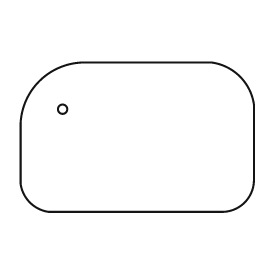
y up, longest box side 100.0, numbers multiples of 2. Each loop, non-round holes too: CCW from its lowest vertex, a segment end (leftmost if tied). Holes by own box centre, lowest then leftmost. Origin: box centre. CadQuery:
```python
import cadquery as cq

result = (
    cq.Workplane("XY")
    .moveTo(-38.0, -32.0)
    .lineTo(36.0, -32.0)
    .threePointArc((46.0, -28.0), (50.0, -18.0))
    .lineTo(50.0, 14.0)
    .threePointArc((44.0, 26.0), (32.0, 32.0))
    .lineTo(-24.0, 32.0)
    .threePointArc((-42.0, 24.0), (-50.0, 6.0))
    .lineTo(-50.0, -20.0)
    .threePointArc((-46.0, -28.0), (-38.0, -32.0))
    .close()
    .moveTo(-32.0, 12.0)
    .circle(2.0)
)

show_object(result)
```